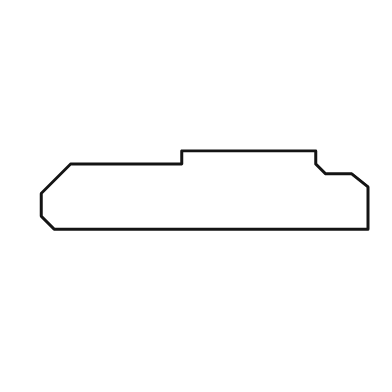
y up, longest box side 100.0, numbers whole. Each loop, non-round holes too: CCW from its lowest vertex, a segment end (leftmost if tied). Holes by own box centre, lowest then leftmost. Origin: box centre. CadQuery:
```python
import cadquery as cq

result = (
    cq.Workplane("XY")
    .moveTo(-46.0, -12.0)
    .lineTo(50.0, -12.0)
    .lineTo(50.0, 1.0)
    .lineTo(45.0, 5.0)
    .lineTo(37.0, 5.0)
    .lineTo(34.0, 8.0)
    .lineTo(34.0, 12.0)
    .lineTo(-7.0, 12.0)
    .lineTo(-7.0, 8.0)
    .lineTo(-41.0, 8.0)
    .lineTo(-50.0, -1.0)
    .lineTo(-50.0, -8.0)
    .close()
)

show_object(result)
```